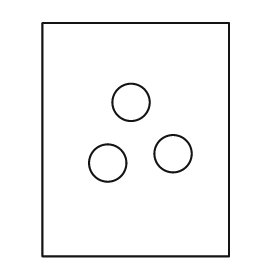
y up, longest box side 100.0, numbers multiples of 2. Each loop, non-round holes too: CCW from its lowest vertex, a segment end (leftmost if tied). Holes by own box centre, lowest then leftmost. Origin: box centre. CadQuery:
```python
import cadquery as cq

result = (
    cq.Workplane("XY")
    .moveTo(-40.0, -50.0)
    .lineTo(40.0, -50.0)
    .lineTo(40.0, 50.0)
    .lineTo(-40.0, 50.0)
    .close()
    .moveTo(-12.0, -10.0)
    .circle(8.0)
    .moveTo(16.0, -6.0)
    .circle(8.0)
    .moveTo(-2.0, 16.0)
    .circle(8.0)
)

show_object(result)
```